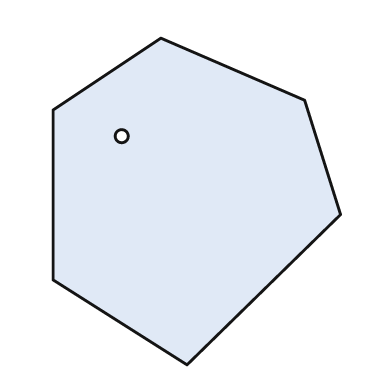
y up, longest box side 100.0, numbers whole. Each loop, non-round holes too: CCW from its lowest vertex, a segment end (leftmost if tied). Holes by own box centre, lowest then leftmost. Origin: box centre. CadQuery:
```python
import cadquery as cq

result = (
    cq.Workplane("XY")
    .moveTo(-3.0, -50.0)
    .lineTo(44.0, -4.0)
    .lineTo(33.0, 31.0)
    .lineTo(-11.0, 50.0)
    .lineTo(-44.0, 28.0)
    .lineTo(-44.0, -24.0)
    .close()
    .moveTo(-23.0, 20.0)
    .circle(2.0)
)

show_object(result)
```